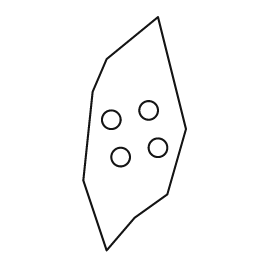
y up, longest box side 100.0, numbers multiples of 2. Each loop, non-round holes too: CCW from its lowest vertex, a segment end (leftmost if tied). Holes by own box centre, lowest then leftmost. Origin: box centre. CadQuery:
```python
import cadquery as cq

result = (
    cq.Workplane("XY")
    .moveTo(-12.0, -50.0)
    .lineTo(0.0, -36.0)
    .lineTo(14.0, -26.0)
    .lineTo(22.0, 2.0)
    .lineTo(10.0, 50.0)
    .lineTo(-12.0, 32.0)
    .lineTo(-18.0, 18.0)
    .lineTo(-22.0, -20.0)
    .close()
    .moveTo(-6.0, -10.0)
    .circle(4.0)
    .moveTo(10.0, -6.0)
    .circle(4.0)
    .moveTo(-10.0, 6.0)
    .circle(4.0)
    .moveTo(6.0, 10.0)
    .circle(4.0)
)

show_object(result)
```